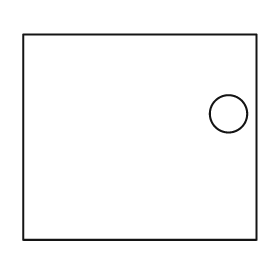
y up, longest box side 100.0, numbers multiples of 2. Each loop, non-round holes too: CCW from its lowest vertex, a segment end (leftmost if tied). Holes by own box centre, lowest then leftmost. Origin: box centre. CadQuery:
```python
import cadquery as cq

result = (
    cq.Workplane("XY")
    .moveTo(-50.0, -44.0)
    .lineTo(50.0, -44.0)
    .lineTo(50.0, 44.0)
    .lineTo(-50.0, 44.0)
    .close()
    .moveTo(38.0, 10.0)
    .circle(8.0)
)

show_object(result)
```